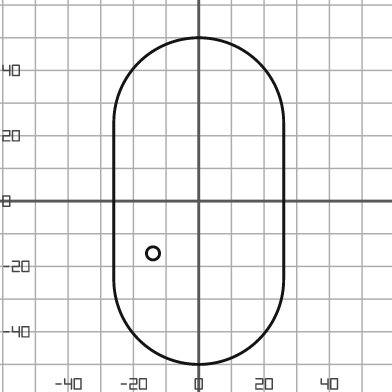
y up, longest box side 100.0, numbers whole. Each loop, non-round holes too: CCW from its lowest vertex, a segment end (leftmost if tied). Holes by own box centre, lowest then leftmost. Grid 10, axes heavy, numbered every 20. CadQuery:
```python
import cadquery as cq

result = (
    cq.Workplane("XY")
    .moveTo(-26.0, -24.0)
    .threePointArc((0.0, -50.0), (26.0, -24.0))
    .lineTo(26.0, 24.0)
    .threePointArc((0.0, 50.0), (-26.0, 24.0))
    .close()
    .moveTo(-14.0, -16.0)
    .circle(2.0)
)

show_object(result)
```